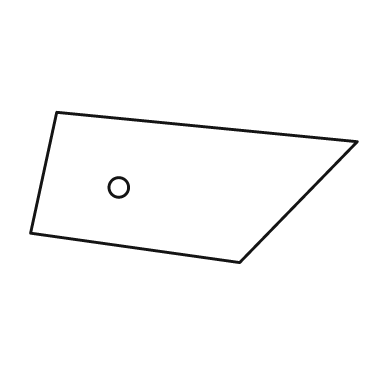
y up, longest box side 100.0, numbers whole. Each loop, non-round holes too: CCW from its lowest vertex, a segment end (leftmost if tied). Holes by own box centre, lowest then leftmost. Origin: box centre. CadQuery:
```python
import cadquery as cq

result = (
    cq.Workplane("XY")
    .moveTo(14.0, -23.0)
    .lineTo(50.0, 14.0)
    .lineTo(-42.0, 23.0)
    .lineTo(-50.0, -14.0)
    .close()
    .moveTo(-23.0, 0.0)
    .circle(3.0)
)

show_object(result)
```